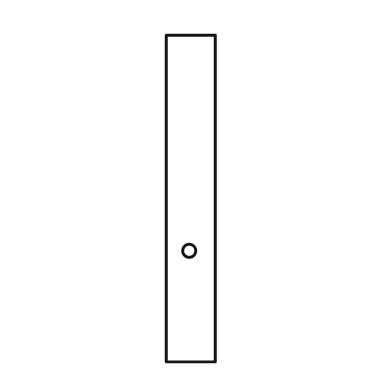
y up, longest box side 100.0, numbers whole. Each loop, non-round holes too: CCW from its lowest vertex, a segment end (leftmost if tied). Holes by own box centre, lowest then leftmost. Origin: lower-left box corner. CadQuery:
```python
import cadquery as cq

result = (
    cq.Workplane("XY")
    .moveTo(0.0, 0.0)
    .lineTo(15.0, 0.0)
    .lineTo(15.0, 100.0)
    .lineTo(0.0, 100.0)
    .close()
    .moveTo(7.0, 34.0)
    .circle(2.0)
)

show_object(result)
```